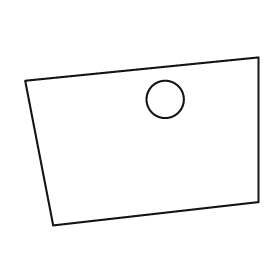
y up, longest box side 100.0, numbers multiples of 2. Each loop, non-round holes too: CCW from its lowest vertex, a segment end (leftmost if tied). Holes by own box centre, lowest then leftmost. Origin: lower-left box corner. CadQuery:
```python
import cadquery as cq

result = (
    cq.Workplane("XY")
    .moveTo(12.0, 0.0)
    .lineTo(100.0, 10.0)
    .lineTo(100.0, 72.0)
    .lineTo(0.0, 62.0)
    .close()
    .moveTo(60.0, 54.0)
    .circle(8.0)
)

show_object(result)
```